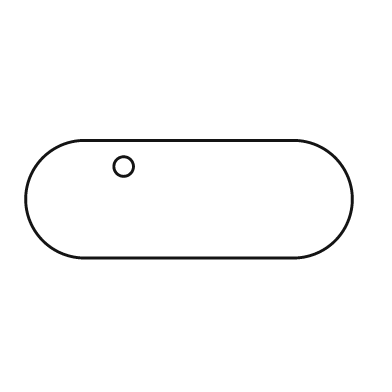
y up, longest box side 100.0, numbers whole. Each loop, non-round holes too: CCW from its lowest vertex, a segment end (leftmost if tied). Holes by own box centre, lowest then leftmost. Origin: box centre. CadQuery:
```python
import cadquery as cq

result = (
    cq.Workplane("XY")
    .moveTo(-32.0, -18.0)
    .lineTo(32.0, -18.0)
    .threePointArc((50.0, 0.0), (32.0, 18.0))
    .lineTo(-32.0, 18.0)
    .threePointArc((-50.0, 0.0), (-32.0, -18.0))
    .close()
    .moveTo(-20.0, 10.0)
    .circle(3.0)
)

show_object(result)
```